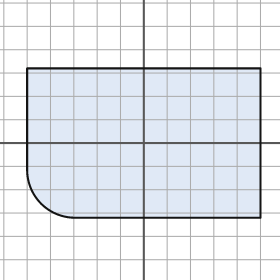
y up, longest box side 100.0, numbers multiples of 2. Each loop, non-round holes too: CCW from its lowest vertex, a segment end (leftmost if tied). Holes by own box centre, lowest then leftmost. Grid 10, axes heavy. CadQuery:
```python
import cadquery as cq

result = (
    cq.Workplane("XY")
    .moveTo(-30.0, -32.0)
    .lineTo(50.0, -32.0)
    .lineTo(50.0, 32.0)
    .lineTo(-50.0, 32.0)
    .lineTo(-50.0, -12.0)
    .threePointArc((-44.0, -26.0), (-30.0, -32.0))
    .close()
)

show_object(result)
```